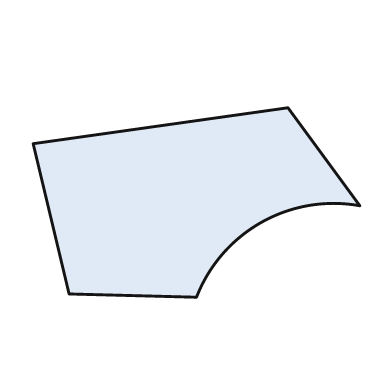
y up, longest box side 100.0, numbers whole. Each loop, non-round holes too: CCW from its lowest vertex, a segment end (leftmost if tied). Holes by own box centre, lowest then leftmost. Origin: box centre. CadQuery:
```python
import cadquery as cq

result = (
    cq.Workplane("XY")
    .moveTo(0.0, -29.0)
    .threePointArc((20.0, -6.0), (50.0, -1.0))
    .lineTo(28.0, 29.0)
    .lineTo(-50.0, 18.0)
    .lineTo(-39.0, -28.0)
    .close()
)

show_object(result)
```